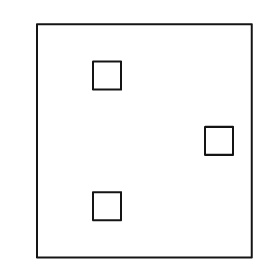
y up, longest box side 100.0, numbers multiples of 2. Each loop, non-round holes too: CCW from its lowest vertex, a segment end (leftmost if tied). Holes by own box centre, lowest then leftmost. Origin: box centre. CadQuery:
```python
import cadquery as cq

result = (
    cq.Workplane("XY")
    .moveTo(-46.0, -50.0)
    .lineTo(46.0, -50.0)
    .lineTo(46.0, 50.0)
    .lineTo(-46.0, 50.0)
    .close()
    .moveTo(-22.0, -34.0)
    .lineTo(-10.0, -34.0)
    .lineTo(-10.0, -22.0)
    .lineTo(-22.0, -22.0)
    .close()
    .moveTo(26.0, -6.0)
    .lineTo(38.0, -6.0)
    .lineTo(38.0, 6.0)
    .lineTo(26.0, 6.0)
    .close()
    .moveTo(-22.0, 22.0)
    .lineTo(-10.0, 22.0)
    .lineTo(-10.0, 34.0)
    .lineTo(-22.0, 34.0)
    .close()
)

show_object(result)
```